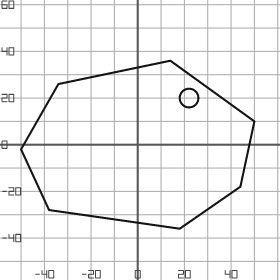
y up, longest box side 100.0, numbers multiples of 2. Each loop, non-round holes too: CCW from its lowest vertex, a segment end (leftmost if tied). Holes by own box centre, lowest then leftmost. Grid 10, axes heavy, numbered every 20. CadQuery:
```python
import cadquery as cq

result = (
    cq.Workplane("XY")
    .moveTo(18.0, -36.0)
    .lineTo(44.0, -18.0)
    .lineTo(50.0, 10.0)
    .lineTo(14.0, 36.0)
    .lineTo(-34.0, 26.0)
    .lineTo(-50.0, -2.0)
    .lineTo(-38.0, -28.0)
    .close()
    .moveTo(22.0, 20.0)
    .circle(4.0)
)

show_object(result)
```